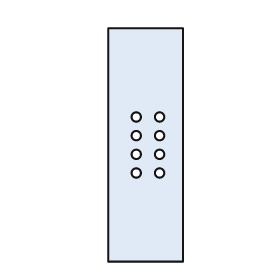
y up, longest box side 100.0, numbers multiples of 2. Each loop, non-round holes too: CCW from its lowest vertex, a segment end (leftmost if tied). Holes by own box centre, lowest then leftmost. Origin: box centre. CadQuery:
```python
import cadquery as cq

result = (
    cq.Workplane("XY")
    .moveTo(-16.0, -50.0)
    .lineTo(16.0, -50.0)
    .lineTo(16.0, 50.0)
    .lineTo(-16.0, 50.0)
    .close()
    .moveTo(-4.0, -12.0)
    .circle(2.0)
    .moveTo(6.0, -12.0)
    .circle(2.0)
    .moveTo(-4.0, -4.0)
    .circle(2.0)
    .moveTo(6.0, -4.0)
    .circle(2.0)
    .moveTo(-4.0, 4.0)
    .circle(2.0)
    .moveTo(6.0, 4.0)
    .circle(2.0)
    .moveTo(-4.0, 12.0)
    .circle(2.0)
    .moveTo(6.0, 12.0)
    .circle(2.0)
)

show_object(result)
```